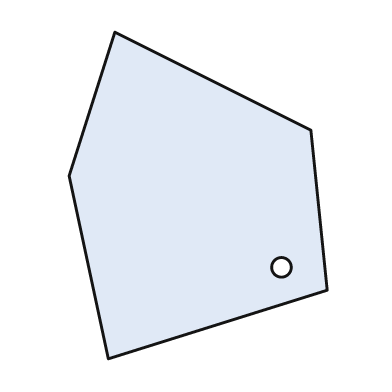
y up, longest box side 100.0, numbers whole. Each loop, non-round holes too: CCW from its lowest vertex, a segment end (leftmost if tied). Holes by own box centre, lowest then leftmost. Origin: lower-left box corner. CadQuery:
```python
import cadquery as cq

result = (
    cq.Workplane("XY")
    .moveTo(12.0, 0.0)
    .lineTo(79.0, 21.0)
    .lineTo(74.0, 70.0)
    .lineTo(14.0, 100.0)
    .lineTo(0.0, 56.0)
    .close()
    .moveTo(65.0, 28.0)
    .circle(3.0)
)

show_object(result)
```